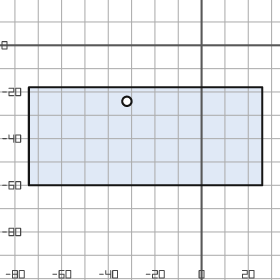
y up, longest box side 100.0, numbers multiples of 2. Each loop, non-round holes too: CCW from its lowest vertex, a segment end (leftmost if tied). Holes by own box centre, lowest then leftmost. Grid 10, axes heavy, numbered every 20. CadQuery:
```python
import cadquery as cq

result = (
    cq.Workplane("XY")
    .moveTo(-74.0, -60.0)
    .lineTo(26.0, -60.0)
    .lineTo(26.0, -18.0)
    .lineTo(-74.0, -18.0)
    .close()
    .moveTo(-32.0, -24.0)
    .circle(2.0)
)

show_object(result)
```